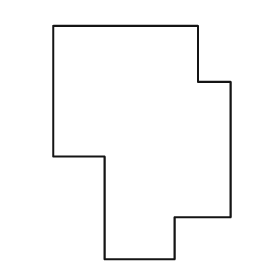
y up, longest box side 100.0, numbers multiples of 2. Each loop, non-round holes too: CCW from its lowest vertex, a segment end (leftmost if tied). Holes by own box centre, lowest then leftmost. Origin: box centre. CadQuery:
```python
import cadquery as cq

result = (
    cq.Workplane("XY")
    .moveTo(-16.0, -50.0)
    .lineTo(14.0, -50.0)
    .lineTo(14.0, -32.0)
    .lineTo(38.0, -32.0)
    .lineTo(38.0, 26.0)
    .lineTo(24.0, 26.0)
    .lineTo(24.0, 50.0)
    .lineTo(-38.0, 50.0)
    .lineTo(-38.0, -6.0)
    .lineTo(-16.0, -6.0)
    .close()
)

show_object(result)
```